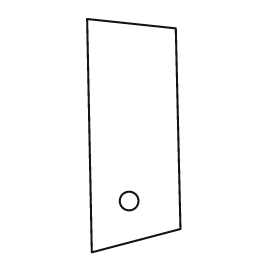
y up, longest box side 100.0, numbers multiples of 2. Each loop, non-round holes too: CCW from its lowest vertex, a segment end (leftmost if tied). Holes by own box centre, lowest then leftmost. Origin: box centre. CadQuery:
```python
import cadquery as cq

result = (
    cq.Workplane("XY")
    .moveTo(-18.0, -50.0)
    .lineTo(20.0, -40.0)
    .lineTo(18.0, 46.0)
    .lineTo(-20.0, 50.0)
    .close()
    .moveTo(-2.0, -28.0)
    .circle(4.0)
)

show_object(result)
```